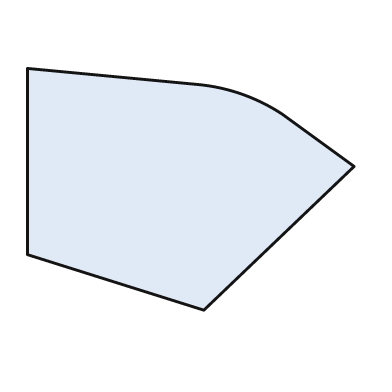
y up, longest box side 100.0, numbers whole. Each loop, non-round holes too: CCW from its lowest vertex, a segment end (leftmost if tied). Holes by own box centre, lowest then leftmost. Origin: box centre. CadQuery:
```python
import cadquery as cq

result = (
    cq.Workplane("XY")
    .moveTo(4.0, -37.0)
    .lineTo(50.0, 7.0)
    .lineTo(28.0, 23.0)
    .threePointArc((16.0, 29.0), (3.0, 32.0))
    .lineTo(-50.0, 37.0)
    .lineTo(-50.0, -20.0)
    .close()
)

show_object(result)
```